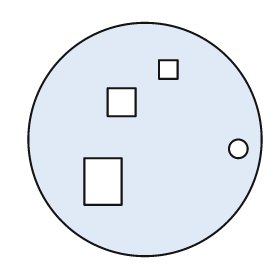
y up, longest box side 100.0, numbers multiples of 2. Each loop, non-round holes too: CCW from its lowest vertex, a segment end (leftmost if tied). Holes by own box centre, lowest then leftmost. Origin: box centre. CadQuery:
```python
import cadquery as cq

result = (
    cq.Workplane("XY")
    .moveTo(0.0, 0.0)
    .circle(50.0)
    .moveTo(-26.0, -28.0)
    .lineTo(-10.0, -28.0)
    .lineTo(-10.0, -8.0)
    .lineTo(-26.0, -8.0)
    .close()
    .moveTo(40.0, -4.0)
    .circle(4.0)
    .moveTo(-16.0, 10.0)
    .lineTo(-4.0, 10.0)
    .lineTo(-4.0, 22.0)
    .lineTo(-16.0, 22.0)
    .close()
    .moveTo(6.0, 26.0)
    .lineTo(14.0, 26.0)
    .lineTo(14.0, 34.0)
    .lineTo(6.0, 34.0)
    .close()
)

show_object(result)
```